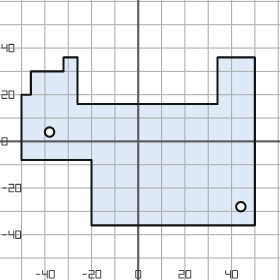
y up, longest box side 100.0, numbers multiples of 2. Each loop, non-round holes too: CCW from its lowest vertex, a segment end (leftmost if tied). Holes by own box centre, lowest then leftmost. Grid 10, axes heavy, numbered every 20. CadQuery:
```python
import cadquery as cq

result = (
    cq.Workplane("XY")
    .moveTo(-20.0, -36.0)
    .lineTo(50.0, -36.0)
    .lineTo(50.0, 36.0)
    .lineTo(34.0, 36.0)
    .lineTo(34.0, 16.0)
    .lineTo(-26.0, 16.0)
    .lineTo(-26.0, 36.0)
    .lineTo(-32.0, 36.0)
    .lineTo(-32.0, 30.0)
    .lineTo(-46.0, 30.0)
    .lineTo(-46.0, 20.0)
    .lineTo(-50.0, 20.0)
    .lineTo(-50.0, -8.0)
    .lineTo(-20.0, -8.0)
    .close()
    .moveTo(44.0, -28.0)
    .circle(2.0)
    .moveTo(-38.0, 4.0)
    .circle(2.0)
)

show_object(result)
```